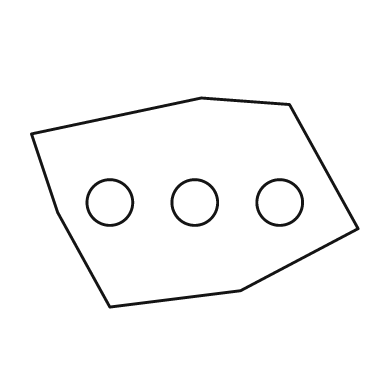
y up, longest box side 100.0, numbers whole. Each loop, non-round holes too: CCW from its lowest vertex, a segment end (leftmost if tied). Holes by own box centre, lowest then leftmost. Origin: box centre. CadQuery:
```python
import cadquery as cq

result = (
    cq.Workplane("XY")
    .moveTo(-26.0, -32.0)
    .lineTo(14.0, -27.0)
    .lineTo(50.0, -8.0)
    .lineTo(29.0, 30.0)
    .lineTo(2.0, 32.0)
    .lineTo(-50.0, 21.0)
    .lineTo(-42.0, -3.0)
    .close()
    .moveTo(-26.0, 0.0)
    .circle(7.0)
    .moveTo(0.0, 0.0)
    .circle(7.0)
    .moveTo(26.0, 0.0)
    .circle(7.0)
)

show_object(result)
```